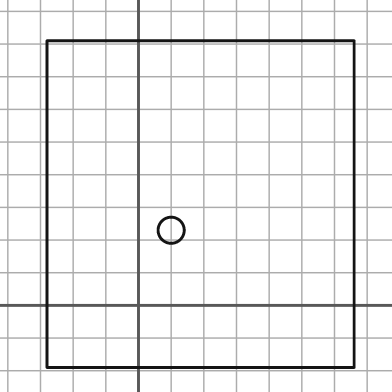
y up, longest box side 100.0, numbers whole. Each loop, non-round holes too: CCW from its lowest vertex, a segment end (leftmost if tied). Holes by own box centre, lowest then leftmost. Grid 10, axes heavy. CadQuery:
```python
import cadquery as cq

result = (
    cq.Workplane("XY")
    .moveTo(-28.0, -19.0)
    .lineTo(66.0, -19.0)
    .lineTo(66.0, 81.0)
    .lineTo(-28.0, 81.0)
    .close()
    .moveTo(10.0, 23.0)
    .circle(4.0)
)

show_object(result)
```